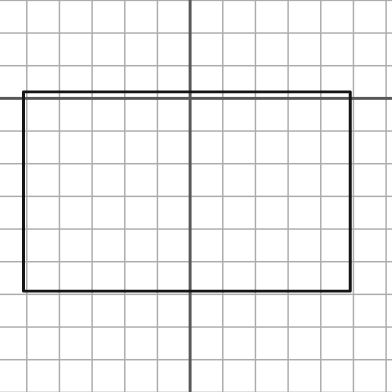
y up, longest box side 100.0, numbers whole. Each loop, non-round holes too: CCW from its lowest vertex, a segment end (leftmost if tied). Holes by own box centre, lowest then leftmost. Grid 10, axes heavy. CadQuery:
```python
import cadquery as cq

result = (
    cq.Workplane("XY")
    .moveTo(-51.0, -59.0)
    .lineTo(49.0, -59.0)
    .lineTo(49.0, 2.0)
    .lineTo(-51.0, 2.0)
    .close()
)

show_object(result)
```